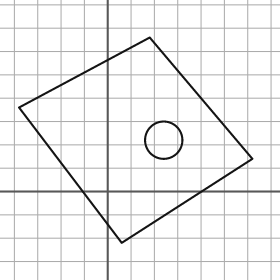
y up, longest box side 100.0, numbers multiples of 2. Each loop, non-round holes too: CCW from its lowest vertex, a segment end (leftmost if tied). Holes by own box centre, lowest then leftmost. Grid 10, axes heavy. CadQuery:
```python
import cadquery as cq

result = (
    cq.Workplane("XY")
    .moveTo(6.0, -22.0)
    .lineTo(62.0, 14.0)
    .lineTo(18.0, 66.0)
    .lineTo(-38.0, 36.0)
    .close()
    .moveTo(24.0, 22.0)
    .circle(8.0)
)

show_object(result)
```